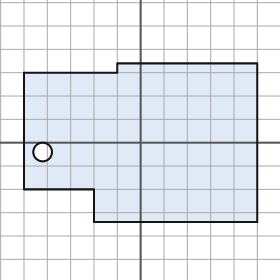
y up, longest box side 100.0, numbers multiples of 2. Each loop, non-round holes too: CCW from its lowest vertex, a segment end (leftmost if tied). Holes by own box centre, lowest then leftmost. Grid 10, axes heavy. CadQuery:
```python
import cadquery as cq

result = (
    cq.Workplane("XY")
    .moveTo(-20.0, -34.0)
    .lineTo(50.0, -34.0)
    .lineTo(50.0, 34.0)
    .lineTo(-10.0, 34.0)
    .lineTo(-10.0, 30.0)
    .lineTo(-50.0, 30.0)
    .lineTo(-50.0, -20.0)
    .lineTo(-20.0, -20.0)
    .close()
    .moveTo(-42.0, -4.0)
    .circle(4.0)
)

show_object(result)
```